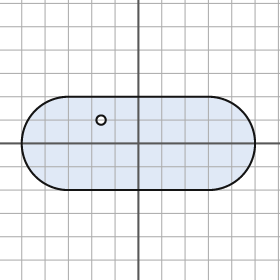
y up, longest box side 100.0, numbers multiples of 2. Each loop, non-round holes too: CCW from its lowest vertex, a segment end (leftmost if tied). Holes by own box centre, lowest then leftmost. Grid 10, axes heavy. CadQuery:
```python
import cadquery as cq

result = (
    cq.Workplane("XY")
    .moveTo(-30.0, -20.0)
    .lineTo(30.0, -20.0)
    .threePointArc((50.0, 0.0), (30.0, 20.0))
    .lineTo(-30.0, 20.0)
    .threePointArc((-50.0, 0.0), (-30.0, -20.0))
    .close()
    .moveTo(-16.0, 10.0)
    .circle(2.0)
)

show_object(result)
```